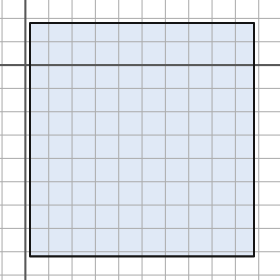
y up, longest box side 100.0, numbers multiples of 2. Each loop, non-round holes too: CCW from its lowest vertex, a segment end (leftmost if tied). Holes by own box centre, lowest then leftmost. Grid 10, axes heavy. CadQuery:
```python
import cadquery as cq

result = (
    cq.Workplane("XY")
    .moveTo(2.0, -82.0)
    .lineTo(98.0, -82.0)
    .lineTo(98.0, 18.0)
    .lineTo(2.0, 18.0)
    .close()
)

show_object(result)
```